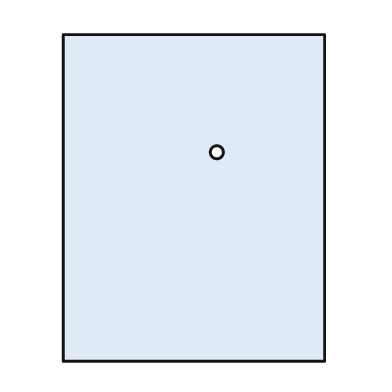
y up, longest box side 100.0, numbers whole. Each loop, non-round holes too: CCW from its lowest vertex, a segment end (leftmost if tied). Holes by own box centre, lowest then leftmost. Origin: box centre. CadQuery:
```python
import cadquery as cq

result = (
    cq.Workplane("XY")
    .moveTo(-40.0, -50.0)
    .lineTo(40.0, -50.0)
    .lineTo(40.0, 50.0)
    .lineTo(-40.0, 50.0)
    .close()
    .moveTo(7.0, 14.0)
    .circle(2.0)
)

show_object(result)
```